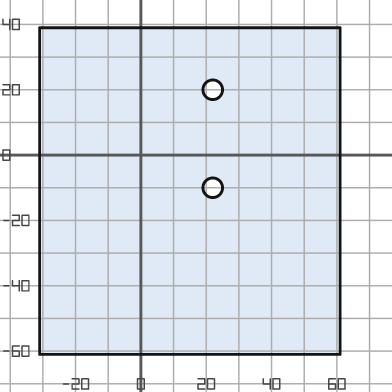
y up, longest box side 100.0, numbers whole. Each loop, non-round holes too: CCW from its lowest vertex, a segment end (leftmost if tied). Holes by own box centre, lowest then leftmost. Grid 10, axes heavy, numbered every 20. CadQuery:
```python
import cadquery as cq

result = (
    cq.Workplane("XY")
    .moveTo(-31.0, -61.0)
    .lineTo(61.0, -61.0)
    .lineTo(61.0, 39.0)
    .lineTo(-31.0, 39.0)
    .close()
    .moveTo(22.0, -10.0)
    .circle(3.0)
    .moveTo(22.0, 20.0)
    .circle(3.0)
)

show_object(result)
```